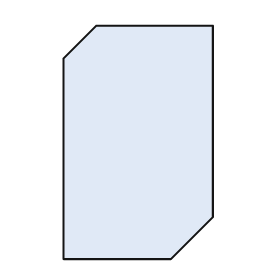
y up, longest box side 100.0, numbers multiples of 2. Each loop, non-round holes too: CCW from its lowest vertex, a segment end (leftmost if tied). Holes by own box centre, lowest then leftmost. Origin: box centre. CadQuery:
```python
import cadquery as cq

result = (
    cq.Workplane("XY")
    .moveTo(-32.0, -50.0)
    .lineTo(14.0, -50.0)
    .lineTo(32.0, -32.0)
    .lineTo(32.0, 50.0)
    .lineTo(-18.0, 50.0)
    .lineTo(-32.0, 36.0)
    .close()
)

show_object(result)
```